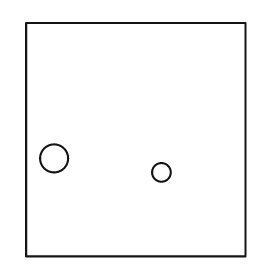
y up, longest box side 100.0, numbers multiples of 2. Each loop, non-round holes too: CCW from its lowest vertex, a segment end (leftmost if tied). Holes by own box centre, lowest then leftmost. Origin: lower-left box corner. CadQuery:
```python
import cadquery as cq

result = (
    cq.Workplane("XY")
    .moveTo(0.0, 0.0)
    .lineTo(94.0, 0.0)
    .lineTo(94.0, 100.0)
    .lineTo(0.0, 100.0)
    .close()
    .moveTo(58.0, 36.0)
    .circle(4.0)
    .moveTo(12.0, 42.0)
    .circle(6.0)
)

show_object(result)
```